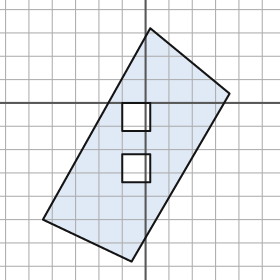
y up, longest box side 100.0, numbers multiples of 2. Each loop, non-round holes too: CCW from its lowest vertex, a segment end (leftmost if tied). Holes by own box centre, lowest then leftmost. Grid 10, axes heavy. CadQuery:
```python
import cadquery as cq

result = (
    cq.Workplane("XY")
    .moveTo(-6.0, -68.0)
    .lineTo(36.0, 4.0)
    .lineTo(2.0, 32.0)
    .lineTo(-44.0, -50.0)
    .close()
    .moveTo(-10.0, -34.0)
    .lineTo(2.0, -34.0)
    .lineTo(2.0, -22.0)
    .lineTo(-10.0, -22.0)
    .close()
    .moveTo(-10.0, -12.0)
    .lineTo(2.0, -12.0)
    .lineTo(2.0, 0.0)
    .lineTo(-10.0, 0.0)
    .close()
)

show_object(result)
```